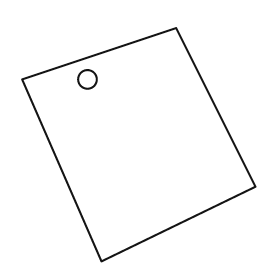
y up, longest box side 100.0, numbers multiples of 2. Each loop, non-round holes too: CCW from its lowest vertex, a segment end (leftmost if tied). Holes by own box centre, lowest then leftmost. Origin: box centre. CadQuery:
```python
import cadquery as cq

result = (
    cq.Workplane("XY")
    .moveTo(-16.0, -50.0)
    .lineTo(50.0, -18.0)
    .lineTo(16.0, 50.0)
    .lineTo(-50.0, 28.0)
    .close()
    .moveTo(-22.0, 28.0)
    .circle(4.0)
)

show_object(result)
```